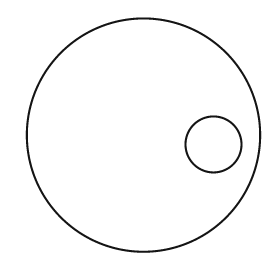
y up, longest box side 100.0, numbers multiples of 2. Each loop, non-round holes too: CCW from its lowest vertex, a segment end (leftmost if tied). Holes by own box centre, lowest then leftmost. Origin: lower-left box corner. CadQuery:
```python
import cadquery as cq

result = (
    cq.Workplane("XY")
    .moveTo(50.0, 50.0)
    .circle(50.0)
    .moveTo(80.0, 46.0)
    .circle(12.0)
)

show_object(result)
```